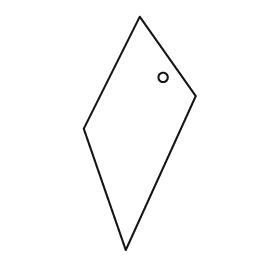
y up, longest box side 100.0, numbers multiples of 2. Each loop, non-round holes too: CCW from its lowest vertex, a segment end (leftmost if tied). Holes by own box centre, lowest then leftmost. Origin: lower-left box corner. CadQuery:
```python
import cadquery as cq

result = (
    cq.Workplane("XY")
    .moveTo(18.0, 0.0)
    .lineTo(48.0, 66.0)
    .lineTo(24.0, 100.0)
    .lineTo(0.0, 52.0)
    .close()
    .moveTo(34.0, 74.0)
    .circle(2.0)
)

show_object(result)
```